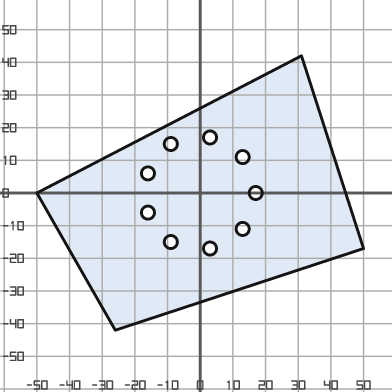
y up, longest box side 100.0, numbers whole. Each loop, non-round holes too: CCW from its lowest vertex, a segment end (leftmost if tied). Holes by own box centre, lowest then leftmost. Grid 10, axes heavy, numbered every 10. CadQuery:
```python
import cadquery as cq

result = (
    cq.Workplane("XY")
    .moveTo(-26.0, -42.0)
    .lineTo(50.0, -17.0)
    .lineTo(31.0, 42.0)
    .lineTo(-50.0, 0.0)
    .close()
    .moveTo(3.0, -17.0)
    .circle(2.0)
    .moveTo(-9.0, -15.0)
    .circle(2.0)
    .moveTo(13.0, -11.0)
    .circle(2.0)
    .moveTo(-16.0, -6.0)
    .circle(2.0)
    .moveTo(17.0, 0.0)
    .circle(2.0)
    .moveTo(-16.0, 6.0)
    .circle(2.0)
    .moveTo(13.0, 11.0)
    .circle(2.0)
    .moveTo(-9.0, 15.0)
    .circle(2.0)
    .moveTo(3.0, 17.0)
    .circle(2.0)
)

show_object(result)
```